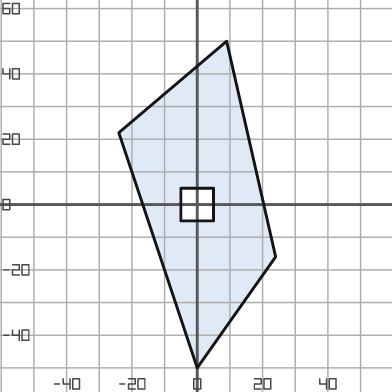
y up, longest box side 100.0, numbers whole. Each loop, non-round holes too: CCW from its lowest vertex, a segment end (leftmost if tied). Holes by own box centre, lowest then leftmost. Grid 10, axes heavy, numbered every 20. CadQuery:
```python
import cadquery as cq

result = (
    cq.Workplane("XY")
    .moveTo(0.0, -50.0)
    .lineTo(24.0, -16.0)
    .lineTo(9.0, 50.0)
    .lineTo(-24.0, 22.0)
    .close()
    .moveTo(-5.0, -5.0)
    .lineTo(5.0, -5.0)
    .lineTo(5.0, 5.0)
    .lineTo(-5.0, 5.0)
    .close()
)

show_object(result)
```